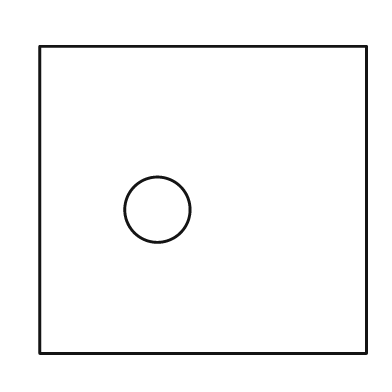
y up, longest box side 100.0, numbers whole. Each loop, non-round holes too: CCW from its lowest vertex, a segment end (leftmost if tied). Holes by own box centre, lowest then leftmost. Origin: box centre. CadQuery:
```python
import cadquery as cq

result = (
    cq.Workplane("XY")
    .moveTo(-50.0, -47.0)
    .lineTo(50.0, -47.0)
    .lineTo(50.0, 47.0)
    .lineTo(-50.0, 47.0)
    .close()
    .moveTo(-14.0, -3.0)
    .circle(10.0)
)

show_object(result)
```